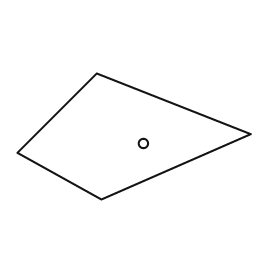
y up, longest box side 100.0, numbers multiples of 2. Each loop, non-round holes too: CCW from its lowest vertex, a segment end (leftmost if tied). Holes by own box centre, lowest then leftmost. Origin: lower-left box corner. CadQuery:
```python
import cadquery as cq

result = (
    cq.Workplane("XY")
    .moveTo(36.0, 0.0)
    .lineTo(100.0, 28.0)
    .lineTo(34.0, 54.0)
    .lineTo(0.0, 20.0)
    .close()
    .moveTo(54.0, 24.0)
    .circle(2.0)
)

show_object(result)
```